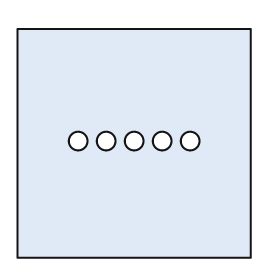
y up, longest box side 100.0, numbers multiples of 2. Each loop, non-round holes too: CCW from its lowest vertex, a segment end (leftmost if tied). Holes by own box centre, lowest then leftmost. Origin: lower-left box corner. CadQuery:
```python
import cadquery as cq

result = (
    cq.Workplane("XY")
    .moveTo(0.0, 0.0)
    .lineTo(100.0, 0.0)
    .lineTo(100.0, 98.0)
    .lineTo(0.0, 98.0)
    .close()
    .moveTo(26.0, 50.0)
    .circle(4.0)
    .moveTo(38.0, 50.0)
    .circle(4.0)
    .moveTo(50.0, 50.0)
    .circle(4.0)
    .moveTo(62.0, 50.0)
    .circle(4.0)
    .moveTo(74.0, 50.0)
    .circle(4.0)
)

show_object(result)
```